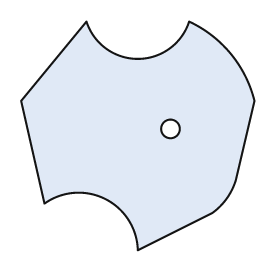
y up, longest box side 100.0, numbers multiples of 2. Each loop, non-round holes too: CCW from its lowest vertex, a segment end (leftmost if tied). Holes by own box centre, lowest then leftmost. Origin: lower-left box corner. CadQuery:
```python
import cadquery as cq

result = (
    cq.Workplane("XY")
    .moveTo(50.0, 0.0)
    .lineTo(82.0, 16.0)
    .threePointArc((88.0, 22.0), (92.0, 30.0))
    .lineTo(100.0, 64.0)
    .threePointArc((90.0, 84.0), (72.0, 98.0))
    .threePointArc((50.0, 82.0), (28.0, 98.0))
    .lineTo(0.0, 64.0)
    .lineTo(10.0, 20.0)
    .threePointArc((36.0, 22.0), (50.0, 0.0))
    .close()
    .moveTo(64.0, 52.0)
    .circle(4.0)
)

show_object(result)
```